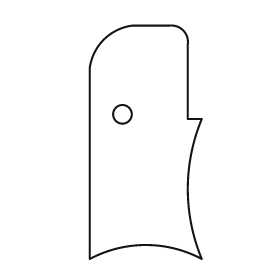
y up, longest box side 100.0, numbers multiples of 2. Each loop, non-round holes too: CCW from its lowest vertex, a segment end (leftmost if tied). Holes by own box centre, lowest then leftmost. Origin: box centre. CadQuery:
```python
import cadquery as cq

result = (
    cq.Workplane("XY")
    .moveTo(-24.0, -50.0)
    .threePointArc((0.0, -44.0), (24.0, -50.0))
    .threePointArc((18.0, -20.0), (24.0, 10.0))
    .lineTo(18.0, 10.0)
    .lineTo(18.0, 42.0)
    .threePointArc((16.0, 48.0), (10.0, 50.0))
    .lineTo(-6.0, 50.0)
    .threePointArc((-18.0, 44.0), (-24.0, 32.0))
    .close()
    .moveTo(-10.0, 12.0)
    .circle(4.0)
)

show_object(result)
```